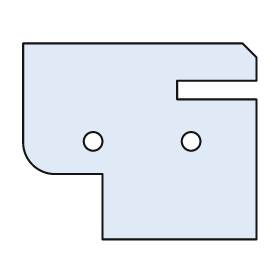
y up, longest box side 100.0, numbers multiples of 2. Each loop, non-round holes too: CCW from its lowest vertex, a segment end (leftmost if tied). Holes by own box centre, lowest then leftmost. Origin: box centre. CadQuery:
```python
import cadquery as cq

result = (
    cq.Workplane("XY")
    .moveTo(-16.0, -42.0)
    .lineTo(50.0, -42.0)
    .lineTo(50.0, 18.0)
    .lineTo(16.0, 18.0)
    .lineTo(16.0, 26.0)
    .lineTo(50.0, 26.0)
    .lineTo(50.0, 36.0)
    .lineTo(44.0, 42.0)
    .lineTo(-50.0, 42.0)
    .lineTo(-50.0, 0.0)
    .threePointArc((-46.0, -10.0), (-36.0, -14.0))
    .lineTo(-16.0, -14.0)
    .close()
    .moveTo(-20.0, 0.0)
    .circle(4.0)
    .moveTo(22.0, 0.0)
    .circle(4.0)
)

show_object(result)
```